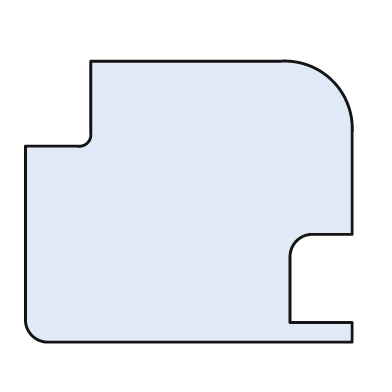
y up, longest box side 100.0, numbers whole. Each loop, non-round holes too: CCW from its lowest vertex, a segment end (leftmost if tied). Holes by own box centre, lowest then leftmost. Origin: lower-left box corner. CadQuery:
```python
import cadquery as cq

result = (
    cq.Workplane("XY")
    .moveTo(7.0, 0.0)
    .lineTo(100.0, 0.0)
    .lineTo(100.0, 6.0)
    .lineTo(81.0, 6.0)
    .lineTo(81.0, 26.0)
    .threePointArc((83.0, 31.0), (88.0, 33.0))
    .lineTo(100.0, 33.0)
    .lineTo(100.0, 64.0)
    .threePointArc((94.0, 80.0), (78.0, 86.0))
    .lineTo(20.0, 86.0)
    .lineTo(20.0, 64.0)
    .threePointArc((19.0, 61.0), (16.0, 60.0))
    .lineTo(0.0, 60.0)
    .lineTo(0.0, 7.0)
    .threePointArc((2.0, 2.0), (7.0, 0.0))
    .close()
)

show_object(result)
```